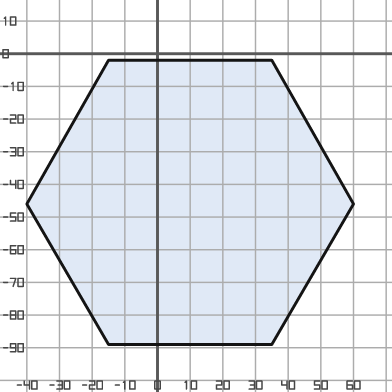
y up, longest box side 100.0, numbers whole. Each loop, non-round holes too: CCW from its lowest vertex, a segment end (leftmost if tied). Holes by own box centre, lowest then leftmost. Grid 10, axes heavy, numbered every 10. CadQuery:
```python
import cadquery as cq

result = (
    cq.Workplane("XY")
    .moveTo(-15.0, -89.0)
    .lineTo(35.0, -89.0)
    .lineTo(60.0, -46.0)
    .lineTo(35.0, -2.0)
    .lineTo(-15.0, -2.0)
    .lineTo(-40.0, -46.0)
    .close()
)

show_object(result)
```